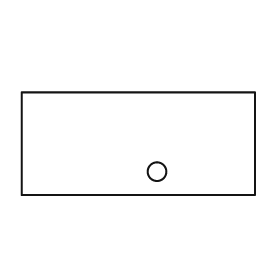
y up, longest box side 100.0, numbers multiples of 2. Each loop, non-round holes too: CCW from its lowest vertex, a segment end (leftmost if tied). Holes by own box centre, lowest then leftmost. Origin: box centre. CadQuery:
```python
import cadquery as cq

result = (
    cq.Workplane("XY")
    .moveTo(-50.0, -22.0)
    .lineTo(50.0, -22.0)
    .lineTo(50.0, 22.0)
    .lineTo(-50.0, 22.0)
    .close()
    .moveTo(8.0, -12.0)
    .circle(4.0)
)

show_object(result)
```